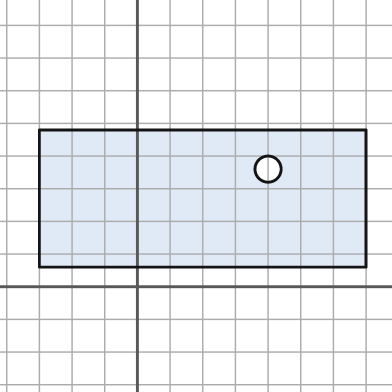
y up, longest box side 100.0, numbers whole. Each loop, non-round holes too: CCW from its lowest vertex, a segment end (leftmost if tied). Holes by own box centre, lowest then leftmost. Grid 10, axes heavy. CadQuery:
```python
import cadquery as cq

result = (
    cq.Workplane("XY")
    .moveTo(-30.0, 6.0)
    .lineTo(70.0, 6.0)
    .lineTo(70.0, 48.0)
    .lineTo(-30.0, 48.0)
    .close()
    .moveTo(40.0, 36.0)
    .circle(4.0)
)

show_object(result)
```